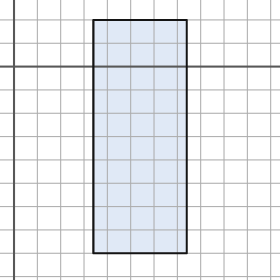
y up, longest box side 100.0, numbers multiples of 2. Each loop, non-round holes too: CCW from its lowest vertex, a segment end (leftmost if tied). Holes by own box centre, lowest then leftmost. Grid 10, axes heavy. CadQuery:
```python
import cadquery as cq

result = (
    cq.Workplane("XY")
    .moveTo(34.0, -80.0)
    .lineTo(74.0, -80.0)
    .lineTo(74.0, 20.0)
    .lineTo(34.0, 20.0)
    .close()
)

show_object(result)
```